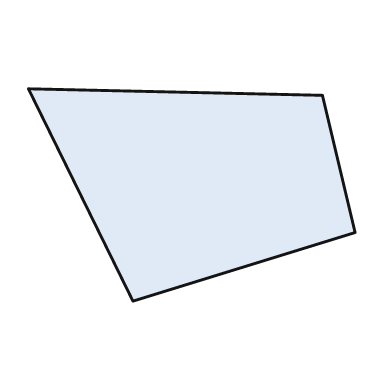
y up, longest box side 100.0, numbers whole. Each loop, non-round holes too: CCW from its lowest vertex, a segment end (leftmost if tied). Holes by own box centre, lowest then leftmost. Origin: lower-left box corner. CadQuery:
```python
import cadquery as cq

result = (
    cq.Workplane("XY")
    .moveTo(32.0, 0.0)
    .lineTo(100.0, 21.0)
    .lineTo(90.0, 63.0)
    .lineTo(0.0, 65.0)
    .close()
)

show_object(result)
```